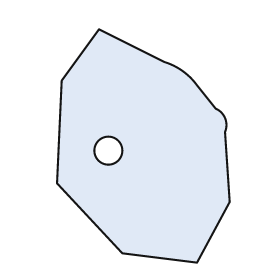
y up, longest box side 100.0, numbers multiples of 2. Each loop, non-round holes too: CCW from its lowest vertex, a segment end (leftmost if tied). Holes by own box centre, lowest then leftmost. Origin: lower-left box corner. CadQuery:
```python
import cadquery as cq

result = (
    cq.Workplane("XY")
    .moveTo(60.0, 0.0)
    .lineTo(74.0, 26.0)
    .lineTo(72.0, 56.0)
    .threePointArc((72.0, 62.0), (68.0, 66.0))
    .lineTo(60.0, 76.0)
    .threePointArc((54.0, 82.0), (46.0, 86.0))
    .lineTo(18.0, 100.0)
    .lineTo(2.0, 78.0)
    .lineTo(0.0, 34.0)
    .lineTo(28.0, 4.0)
    .close()
    .moveTo(22.0, 48.0)
    .circle(6.0)
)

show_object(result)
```